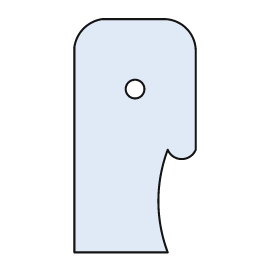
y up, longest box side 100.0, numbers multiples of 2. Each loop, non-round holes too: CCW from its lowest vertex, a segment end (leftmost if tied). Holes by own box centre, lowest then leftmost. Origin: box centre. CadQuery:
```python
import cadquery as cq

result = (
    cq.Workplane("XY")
    .moveTo(-26.0, -50.0)
    .lineTo(14.0, -50.0)
    .threePointArc((10.0, -28.0), (14.0, -6.0))
    .threePointArc((20.0, -10.0), (26.0, -6.0))
    .lineTo(26.0, 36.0)
    .threePointArc((22.0, 46.0), (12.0, 50.0))
    .lineTo(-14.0, 50.0)
    .threePointArc((-22.0, 46.0), (-26.0, 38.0))
    .close()
    .moveTo(0.0, 20.0)
    .circle(4.0)
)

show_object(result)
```